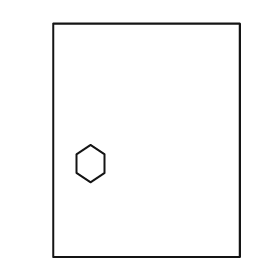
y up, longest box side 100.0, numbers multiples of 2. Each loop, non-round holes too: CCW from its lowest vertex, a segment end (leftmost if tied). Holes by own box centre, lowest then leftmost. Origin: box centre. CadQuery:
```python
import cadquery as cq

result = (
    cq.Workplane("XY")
    .moveTo(-40.0, -50.0)
    .lineTo(40.0, -50.0)
    .lineTo(40.0, 50.0)
    .lineTo(-40.0, 50.0)
    .close()
    .moveTo(-24.0, -18.0)
    .lineTo(-18.0, -14.0)
    .lineTo(-18.0, -6.0)
    .lineTo(-24.0, -2.0)
    .lineTo(-30.0, -6.0)
    .lineTo(-30.0, -14.0)
    .close()
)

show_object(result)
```